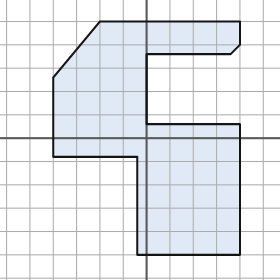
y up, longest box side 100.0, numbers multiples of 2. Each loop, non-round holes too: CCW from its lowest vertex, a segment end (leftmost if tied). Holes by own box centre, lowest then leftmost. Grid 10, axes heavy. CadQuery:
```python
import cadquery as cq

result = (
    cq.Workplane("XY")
    .moveTo(-4.0, -50.0)
    .lineTo(40.0, -50.0)
    .lineTo(40.0, 6.0)
    .lineTo(0.0, 6.0)
    .lineTo(0.0, 36.0)
    .lineTo(36.0, 36.0)
    .lineTo(40.0, 40.0)
    .lineTo(40.0, 50.0)
    .lineTo(-20.0, 50.0)
    .lineTo(-40.0, 26.0)
    .lineTo(-40.0, -8.0)
    .lineTo(-4.0, -8.0)
    .close()
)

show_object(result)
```